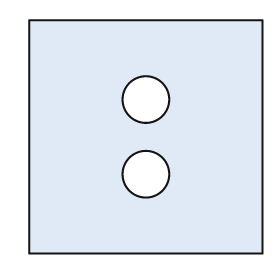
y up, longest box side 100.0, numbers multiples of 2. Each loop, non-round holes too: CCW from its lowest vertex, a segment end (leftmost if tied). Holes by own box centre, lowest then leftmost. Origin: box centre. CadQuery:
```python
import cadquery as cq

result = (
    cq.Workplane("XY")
    .moveTo(-50.0, -50.0)
    .lineTo(50.0, -50.0)
    .lineTo(50.0, 50.0)
    .lineTo(-50.0, 50.0)
    .close()
    .moveTo(0.0, -16.0)
    .circle(10.0)
    .moveTo(0.0, 16.0)
    .circle(10.0)
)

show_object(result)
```